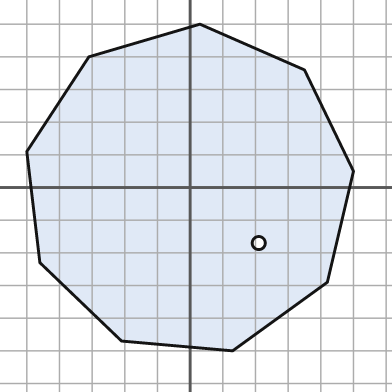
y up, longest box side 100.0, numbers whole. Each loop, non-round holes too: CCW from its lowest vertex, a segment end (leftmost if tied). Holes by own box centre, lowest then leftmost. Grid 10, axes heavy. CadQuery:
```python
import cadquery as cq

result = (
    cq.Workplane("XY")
    .moveTo(13.0, -50.0)
    .lineTo(42.0, -29.0)
    .lineTo(50.0, 5.0)
    .lineTo(35.0, 36.0)
    .lineTo(3.0, 50.0)
    .lineTo(-31.0, 40.0)
    .lineTo(-50.0, 11.0)
    .lineTo(-46.0, -23.0)
    .lineTo(-21.0, -47.0)
    .close()
    .moveTo(21.0, -17.0)
    .circle(2.0)
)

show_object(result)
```